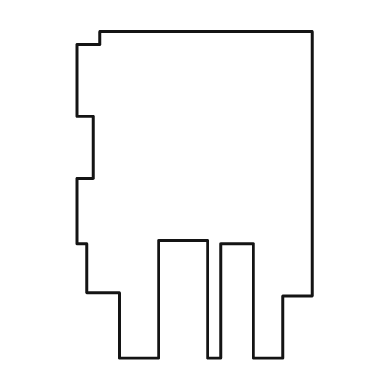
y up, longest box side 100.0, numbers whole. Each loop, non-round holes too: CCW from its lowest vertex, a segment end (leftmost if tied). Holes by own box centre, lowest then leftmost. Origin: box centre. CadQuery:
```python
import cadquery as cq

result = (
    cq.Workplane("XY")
    .moveTo(-23.0, -50.0)
    .lineTo(-11.0, -50.0)
    .lineTo(-11.0, -14.0)
    .lineTo(4.0, -14.0)
    .lineTo(4.0, -50.0)
    .lineTo(8.0, -50.0)
    .lineTo(8.0, -15.0)
    .lineTo(18.0, -15.0)
    .lineTo(18.0, -50.0)
    .lineTo(27.0, -50.0)
    .lineTo(27.0, -31.0)
    .lineTo(36.0, -31.0)
    .lineTo(36.0, 50.0)
    .lineTo(-29.0, 50.0)
    .lineTo(-29.0, 46.0)
    .lineTo(-36.0, 46.0)
    .lineTo(-36.0, 24.0)
    .lineTo(-31.0, 24.0)
    .lineTo(-31.0, 5.0)
    .lineTo(-36.0, 5.0)
    .lineTo(-36.0, -15.0)
    .lineTo(-33.0, -15.0)
    .lineTo(-33.0, -30.0)
    .lineTo(-23.0, -30.0)
    .close()
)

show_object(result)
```